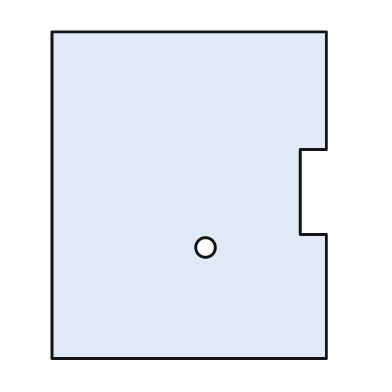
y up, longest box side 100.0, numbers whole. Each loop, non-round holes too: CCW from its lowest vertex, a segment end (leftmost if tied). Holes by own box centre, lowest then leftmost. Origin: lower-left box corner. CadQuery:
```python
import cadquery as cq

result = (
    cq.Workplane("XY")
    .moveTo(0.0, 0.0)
    .lineTo(84.0, 0.0)
    .lineTo(84.0, 38.0)
    .lineTo(76.0, 38.0)
    .lineTo(76.0, 64.0)
    .lineTo(84.0, 64.0)
    .lineTo(84.0, 100.0)
    .lineTo(0.0, 100.0)
    .close()
    .moveTo(47.0, 34.0)
    .circle(3.0)
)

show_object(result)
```